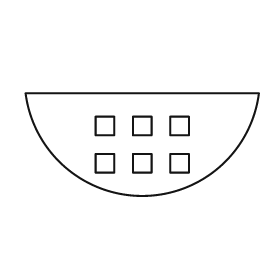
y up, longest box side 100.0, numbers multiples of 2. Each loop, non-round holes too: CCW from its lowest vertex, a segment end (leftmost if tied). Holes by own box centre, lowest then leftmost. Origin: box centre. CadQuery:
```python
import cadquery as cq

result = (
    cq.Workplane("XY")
    .moveTo(-50.0, 22.0)
    .threePointArc((0.0, -22.0), (50.0, 22.0))
    .close()
    .moveTo(-20.0, -12.0)
    .lineTo(-12.0, -12.0)
    .lineTo(-12.0, -4.0)
    .lineTo(-20.0, -4.0)
    .close()
    .moveTo(-4.0, -12.0)
    .lineTo(4.0, -12.0)
    .lineTo(4.0, -4.0)
    .lineTo(-4.0, -4.0)
    .close()
    .moveTo(12.0, -12.0)
    .lineTo(20.0, -12.0)
    .lineTo(20.0, -4.0)
    .lineTo(12.0, -4.0)
    .close()
    .moveTo(-20.0, 4.0)
    .lineTo(-12.0, 4.0)
    .lineTo(-12.0, 12.0)
    .lineTo(-20.0, 12.0)
    .close()
    .moveTo(-4.0, 4.0)
    .lineTo(4.0, 4.0)
    .lineTo(4.0, 12.0)
    .lineTo(-4.0, 12.0)
    .close()
    .moveTo(12.0, 4.0)
    .lineTo(20.0, 4.0)
    .lineTo(20.0, 12.0)
    .lineTo(12.0, 12.0)
    .close()
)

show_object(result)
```